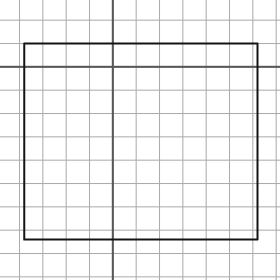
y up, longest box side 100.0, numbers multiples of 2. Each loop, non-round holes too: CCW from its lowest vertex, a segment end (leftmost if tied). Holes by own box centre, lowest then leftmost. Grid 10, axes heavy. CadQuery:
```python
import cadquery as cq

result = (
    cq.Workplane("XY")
    .moveTo(-38.0, -74.0)
    .lineTo(62.0, -74.0)
    .lineTo(62.0, 10.0)
    .lineTo(-38.0, 10.0)
    .close()
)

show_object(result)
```